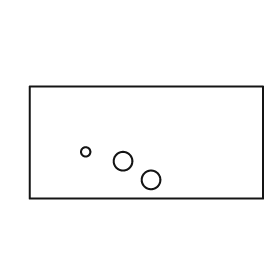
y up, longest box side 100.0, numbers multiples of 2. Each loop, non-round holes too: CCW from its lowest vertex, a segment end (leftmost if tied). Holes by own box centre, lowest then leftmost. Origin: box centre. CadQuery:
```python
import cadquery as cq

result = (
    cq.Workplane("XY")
    .moveTo(-50.0, -24.0)
    .lineTo(50.0, -24.0)
    .lineTo(50.0, 24.0)
    .lineTo(-50.0, 24.0)
    .close()
    .moveTo(2.0, -16.0)
    .circle(4.0)
    .moveTo(-10.0, -8.0)
    .circle(4.0)
    .moveTo(-26.0, -4.0)
    .circle(2.0)
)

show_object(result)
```